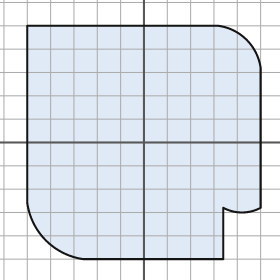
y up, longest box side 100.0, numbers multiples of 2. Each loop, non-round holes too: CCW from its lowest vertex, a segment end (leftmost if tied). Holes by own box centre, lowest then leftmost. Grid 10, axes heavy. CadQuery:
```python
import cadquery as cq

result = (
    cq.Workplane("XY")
    .moveTo(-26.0, -50.0)
    .lineTo(34.0, -50.0)
    .lineTo(34.0, -28.0)
    .threePointArc((42.0, -30.0), (50.0, -28.0))
    .lineTo(50.0, 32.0)
    .threePointArc((44.0, 44.0), (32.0, 50.0))
    .lineTo(-50.0, 50.0)
    .lineTo(-50.0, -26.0)
    .threePointArc((-42.0, -42.0), (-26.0, -50.0))
    .close()
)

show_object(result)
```